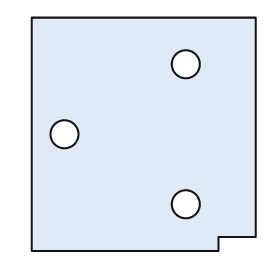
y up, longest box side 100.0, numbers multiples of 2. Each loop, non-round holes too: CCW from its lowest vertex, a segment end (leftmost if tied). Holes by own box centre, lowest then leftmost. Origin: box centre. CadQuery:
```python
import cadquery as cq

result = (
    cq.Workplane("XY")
    .moveTo(-48.0, -50.0)
    .lineTo(32.0, -50.0)
    .lineTo(32.0, -44.0)
    .lineTo(48.0, -44.0)
    .lineTo(48.0, 50.0)
    .lineTo(-48.0, 50.0)
    .close()
    .moveTo(18.0, -30.0)
    .circle(6.0)
    .moveTo(-34.0, 0.0)
    .circle(6.0)
    .moveTo(18.0, 30.0)
    .circle(6.0)
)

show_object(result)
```